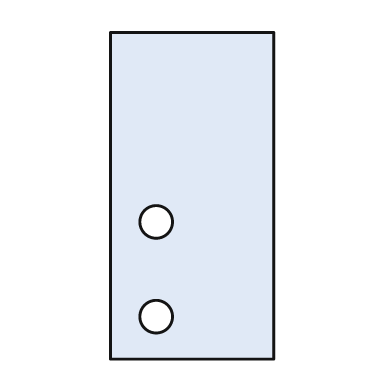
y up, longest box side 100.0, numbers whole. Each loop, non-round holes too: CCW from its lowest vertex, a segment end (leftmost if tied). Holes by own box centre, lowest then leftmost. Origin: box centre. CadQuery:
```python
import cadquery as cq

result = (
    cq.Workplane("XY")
    .moveTo(-25.0, -50.0)
    .lineTo(25.0, -50.0)
    .lineTo(25.0, 50.0)
    .lineTo(-25.0, 50.0)
    .close()
    .moveTo(-11.0, -37.0)
    .circle(5.0)
    .moveTo(-11.0, -8.0)
    .circle(5.0)
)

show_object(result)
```